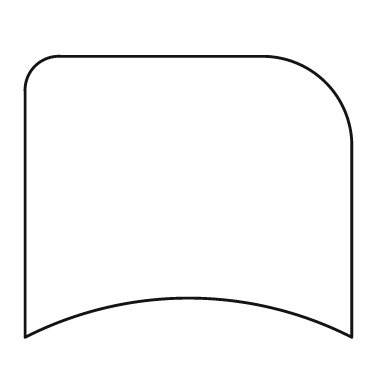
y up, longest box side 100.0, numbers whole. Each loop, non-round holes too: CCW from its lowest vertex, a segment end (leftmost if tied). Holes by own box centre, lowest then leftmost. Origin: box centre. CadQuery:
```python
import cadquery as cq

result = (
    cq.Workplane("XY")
    .moveTo(-50.0, -43.0)
    .threePointArc((0.0, -31.0), (50.0, -43.0))
    .lineTo(50.0, 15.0)
    .threePointArc((42.0, 35.0), (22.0, 43.0))
    .lineTo(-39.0, 43.0)
    .threePointArc((-47.0, 40.0), (-50.0, 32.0))
    .close()
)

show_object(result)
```